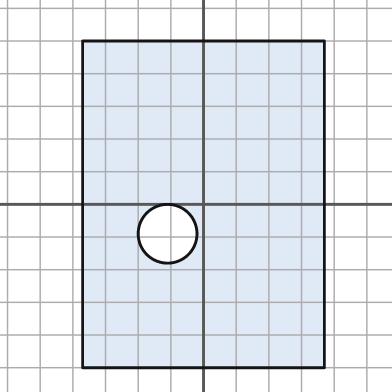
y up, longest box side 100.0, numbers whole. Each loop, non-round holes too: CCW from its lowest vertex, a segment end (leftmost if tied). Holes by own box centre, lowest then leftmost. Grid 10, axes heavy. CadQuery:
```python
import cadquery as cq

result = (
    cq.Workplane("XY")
    .moveTo(-37.0, -50.0)
    .lineTo(37.0, -50.0)
    .lineTo(37.0, 50.0)
    .lineTo(-37.0, 50.0)
    .close()
    .moveTo(-11.0, -9.0)
    .circle(9.0)
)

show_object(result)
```